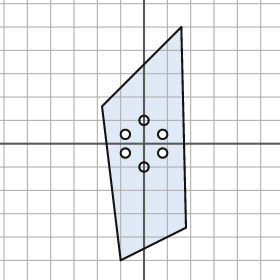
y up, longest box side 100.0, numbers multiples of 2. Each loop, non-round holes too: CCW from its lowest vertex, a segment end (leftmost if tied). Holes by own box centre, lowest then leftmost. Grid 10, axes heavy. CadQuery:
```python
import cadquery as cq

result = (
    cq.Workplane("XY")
    .moveTo(-10.0, -50.0)
    .lineTo(18.0, -36.0)
    .lineTo(16.0, 50.0)
    .lineTo(-18.0, 16.0)
    .close()
    .moveTo(0.0, -10.0)
    .circle(2.0)
    .moveTo(-8.0, -4.0)
    .circle(2.0)
    .moveTo(8.0, -4.0)
    .circle(2.0)
    .moveTo(-8.0, 4.0)
    .circle(2.0)
    .moveTo(8.0, 4.0)
    .circle(2.0)
    .moveTo(0.0, 10.0)
    .circle(2.0)
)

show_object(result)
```